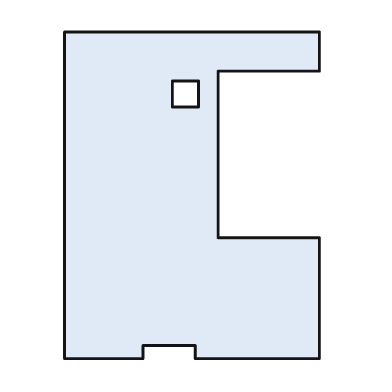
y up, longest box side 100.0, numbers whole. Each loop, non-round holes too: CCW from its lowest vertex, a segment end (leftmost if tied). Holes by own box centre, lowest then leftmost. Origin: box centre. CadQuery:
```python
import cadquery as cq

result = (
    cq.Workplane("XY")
    .moveTo(-39.0, -50.0)
    .lineTo(-15.0, -50.0)
    .lineTo(-15.0, -46.0)
    .lineTo(1.0, -46.0)
    .lineTo(1.0, -50.0)
    .lineTo(39.0, -50.0)
    .lineTo(39.0, -13.0)
    .lineTo(8.0, -13.0)
    .lineTo(8.0, 38.0)
    .lineTo(39.0, 38.0)
    .lineTo(39.0, 50.0)
    .lineTo(-39.0, 50.0)
    .close()
    .moveTo(-6.0, 27.0)
    .lineTo(2.0, 27.0)
    .lineTo(2.0, 35.0)
    .lineTo(-6.0, 35.0)
    .close()
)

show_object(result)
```